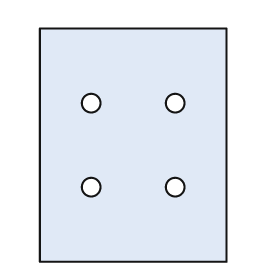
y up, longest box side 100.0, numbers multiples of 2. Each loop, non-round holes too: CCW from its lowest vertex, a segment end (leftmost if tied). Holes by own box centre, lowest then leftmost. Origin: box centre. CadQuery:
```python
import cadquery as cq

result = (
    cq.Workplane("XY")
    .moveTo(-40.0, -50.0)
    .lineTo(40.0, -50.0)
    .lineTo(40.0, 50.0)
    .lineTo(-40.0, 50.0)
    .close()
    .moveTo(-18.0, -18.0)
    .circle(4.0)
    .moveTo(18.0, -18.0)
    .circle(4.0)
    .moveTo(-18.0, 18.0)
    .circle(4.0)
    .moveTo(18.0, 18.0)
    .circle(4.0)
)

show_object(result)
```